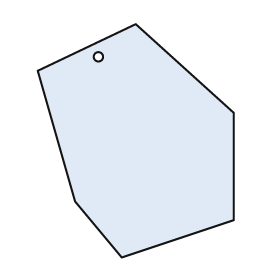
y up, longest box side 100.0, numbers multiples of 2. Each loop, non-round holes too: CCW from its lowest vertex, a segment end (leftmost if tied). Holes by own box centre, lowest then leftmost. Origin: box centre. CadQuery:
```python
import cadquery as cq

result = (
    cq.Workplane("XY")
    .moveTo(-6.0, -50.0)
    .lineTo(42.0, -34.0)
    .lineTo(42.0, 12.0)
    .lineTo(0.0, 50.0)
    .lineTo(-42.0, 30.0)
    .lineTo(-26.0, -26.0)
    .close()
    .moveTo(-16.0, 36.0)
    .circle(2.0)
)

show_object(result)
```